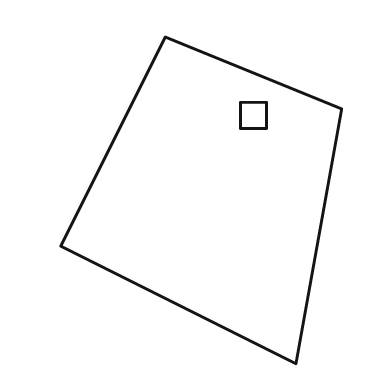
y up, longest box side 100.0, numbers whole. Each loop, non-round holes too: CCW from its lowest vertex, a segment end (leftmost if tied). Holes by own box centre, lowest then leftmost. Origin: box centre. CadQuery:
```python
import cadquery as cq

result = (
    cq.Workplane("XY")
    .moveTo(29.0, -50.0)
    .lineTo(43.0, 28.0)
    .lineTo(-11.0, 50.0)
    .lineTo(-43.0, -14.0)
    .close()
    .moveTo(12.0, 22.0)
    .lineTo(20.0, 22.0)
    .lineTo(20.0, 30.0)
    .lineTo(12.0, 30.0)
    .close()
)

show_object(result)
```